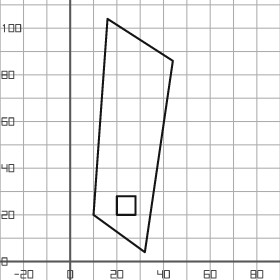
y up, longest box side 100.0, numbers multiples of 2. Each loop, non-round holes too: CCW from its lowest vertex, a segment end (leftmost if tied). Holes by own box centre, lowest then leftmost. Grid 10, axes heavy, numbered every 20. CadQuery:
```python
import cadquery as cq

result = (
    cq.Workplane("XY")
    .moveTo(32.0, 4.0)
    .lineTo(44.0, 86.0)
    .lineTo(16.0, 104.0)
    .lineTo(10.0, 20.0)
    .close()
    .moveTo(20.0, 20.0)
    .lineTo(28.0, 20.0)
    .lineTo(28.0, 28.0)
    .lineTo(20.0, 28.0)
    .close()
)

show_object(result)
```